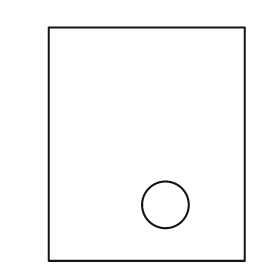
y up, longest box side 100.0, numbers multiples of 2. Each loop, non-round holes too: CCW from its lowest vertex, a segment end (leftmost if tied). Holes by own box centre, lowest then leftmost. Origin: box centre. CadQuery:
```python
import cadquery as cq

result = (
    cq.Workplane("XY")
    .moveTo(-42.0, -50.0)
    .lineTo(42.0, -50.0)
    .lineTo(42.0, 50.0)
    .lineTo(-42.0, 50.0)
    .close()
    .moveTo(8.0, -26.0)
    .circle(10.0)
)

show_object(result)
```